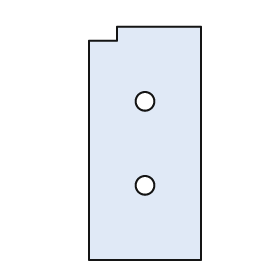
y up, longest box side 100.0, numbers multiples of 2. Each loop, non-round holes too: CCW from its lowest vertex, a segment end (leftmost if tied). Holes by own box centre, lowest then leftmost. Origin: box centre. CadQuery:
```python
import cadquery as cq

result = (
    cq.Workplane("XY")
    .moveTo(-24.0, -50.0)
    .lineTo(24.0, -50.0)
    .lineTo(24.0, 50.0)
    .lineTo(-12.0, 50.0)
    .lineTo(-12.0, 44.0)
    .lineTo(-24.0, 44.0)
    .close()
    .moveTo(0.0, -18.0)
    .circle(4.0)
    .moveTo(0.0, 18.0)
    .circle(4.0)
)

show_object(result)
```